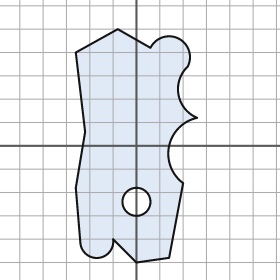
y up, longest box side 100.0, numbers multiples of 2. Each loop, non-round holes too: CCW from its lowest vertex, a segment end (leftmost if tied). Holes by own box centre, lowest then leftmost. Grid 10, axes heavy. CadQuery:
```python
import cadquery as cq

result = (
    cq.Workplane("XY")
    .moveTo(0.0, -50.0)
    .lineTo(14.0, -48.0)
    .lineTo(20.0, -16.0)
    .threePointArc((14.0, 0.0), (26.0, 12.0))
    .threePointArc((18.0, 22.0), (22.0, 34.0))
    .threePointArc((18.0, 46.0), (6.0, 42.0))
    .lineTo(-8.0, 50.0)
    .lineTo(-26.0, 40.0)
    .lineTo(-22.0, 6.0)
    .lineTo(-26.0, -18.0)
    .lineTo(-24.0, -42.0)
    .threePointArc((-16.0, -48.0), (-10.0, -40.0))
    .close()
    .moveTo(0.0, -24.0)
    .circle(6.0)
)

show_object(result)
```